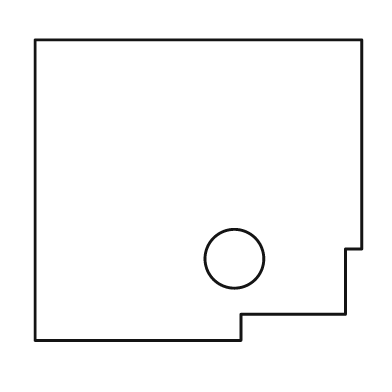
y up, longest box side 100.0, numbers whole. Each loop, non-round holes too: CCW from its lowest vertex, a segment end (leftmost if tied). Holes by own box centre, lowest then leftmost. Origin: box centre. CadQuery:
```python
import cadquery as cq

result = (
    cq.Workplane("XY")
    .moveTo(-50.0, -46.0)
    .lineTo(13.0, -46.0)
    .lineTo(13.0, -38.0)
    .lineTo(45.0, -38.0)
    .lineTo(45.0, -18.0)
    .lineTo(50.0, -18.0)
    .lineTo(50.0, 46.0)
    .lineTo(-50.0, 46.0)
    .close()
    .moveTo(11.0, -21.0)
    .circle(9.0)
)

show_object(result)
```